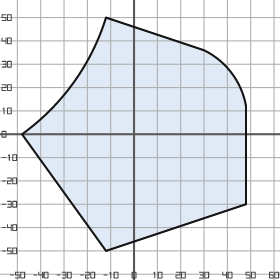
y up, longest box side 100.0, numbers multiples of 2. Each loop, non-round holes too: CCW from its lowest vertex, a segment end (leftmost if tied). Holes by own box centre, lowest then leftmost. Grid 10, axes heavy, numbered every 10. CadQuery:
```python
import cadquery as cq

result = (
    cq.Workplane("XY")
    .moveTo(-12.0, -50.0)
    .lineTo(48.0, -30.0)
    .lineTo(48.0, 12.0)
    .threePointArc((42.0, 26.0), (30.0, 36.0))
    .lineTo(-12.0, 50.0)
    .threePointArc((-26.0, 22.0), (-48.0, 0.0))
    .close()
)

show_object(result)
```